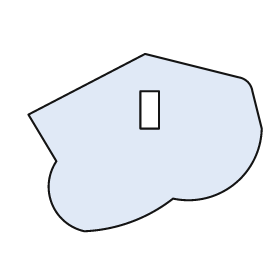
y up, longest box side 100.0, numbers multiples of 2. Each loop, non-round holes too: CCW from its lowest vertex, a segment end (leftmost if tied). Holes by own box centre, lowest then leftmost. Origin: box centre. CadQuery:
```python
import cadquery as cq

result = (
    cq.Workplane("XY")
    .moveTo(-26.0, -38.0)
    .threePointArc((-6.0, -34.0), (12.0, -24.0))
    .threePointArc((38.0, -18.0), (50.0, 6.0))
    .lineTo(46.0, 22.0)
    .threePointArc((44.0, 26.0), (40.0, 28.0))
    .lineTo(0.0, 38.0)
    .lineTo(-50.0, 12.0)
    .lineTo(-38.0, -8.0)
    .threePointArc((-40.0, -26.0), (-26.0, -38.0))
    .close()
    .moveTo(-2.0, 6.0)
    .lineTo(6.0, 6.0)
    .lineTo(6.0, 22.0)
    .lineTo(-2.0, 22.0)
    .close()
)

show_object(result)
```